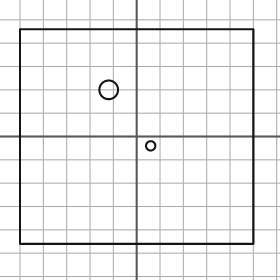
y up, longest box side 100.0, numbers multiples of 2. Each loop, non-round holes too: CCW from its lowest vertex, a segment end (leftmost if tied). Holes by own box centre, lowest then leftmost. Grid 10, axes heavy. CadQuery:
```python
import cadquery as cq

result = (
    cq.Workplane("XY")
    .moveTo(-50.0, -46.0)
    .lineTo(50.0, -46.0)
    .lineTo(50.0, 46.0)
    .lineTo(-50.0, 46.0)
    .close()
    .moveTo(6.0, -4.0)
    .circle(2.0)
    .moveTo(-12.0, 20.0)
    .circle(4.0)
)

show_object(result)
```